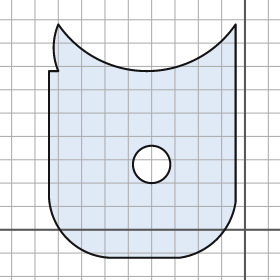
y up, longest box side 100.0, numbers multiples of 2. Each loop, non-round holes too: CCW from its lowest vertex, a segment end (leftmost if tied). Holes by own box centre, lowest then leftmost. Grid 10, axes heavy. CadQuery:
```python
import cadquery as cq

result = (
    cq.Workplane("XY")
    .moveTo(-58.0, -12.0)
    .lineTo(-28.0, -12.0)
    .threePointArc((-12.0, -4.0), (-4.0, 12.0))
    .lineTo(-4.0, 88.0)
    .threePointArc((-42.0, 68.0), (-80.0, 88.0))
    .threePointArc((-82.0, 78.0), (-80.0, 68.0))
    .lineTo(-84.0, 68.0)
    .lineTo(-84.0, 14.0)
    .threePointArc((-76.0, -4.0), (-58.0, -12.0))
    .close()
    .moveTo(-40.0, 28.0)
    .circle(8.0)
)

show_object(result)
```